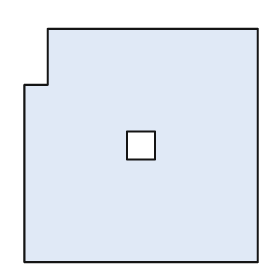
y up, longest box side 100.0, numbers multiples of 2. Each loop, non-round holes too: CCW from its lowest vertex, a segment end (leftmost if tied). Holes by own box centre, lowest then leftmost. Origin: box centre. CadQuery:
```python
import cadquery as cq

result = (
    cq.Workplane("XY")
    .moveTo(-50.0, -50.0)
    .lineTo(50.0, -50.0)
    .lineTo(50.0, 50.0)
    .lineTo(-40.0, 50.0)
    .lineTo(-40.0, 26.0)
    .lineTo(-50.0, 26.0)
    .close()
    .moveTo(-6.0, -6.0)
    .lineTo(6.0, -6.0)
    .lineTo(6.0, 6.0)
    .lineTo(-6.0, 6.0)
    .close()
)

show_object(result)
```